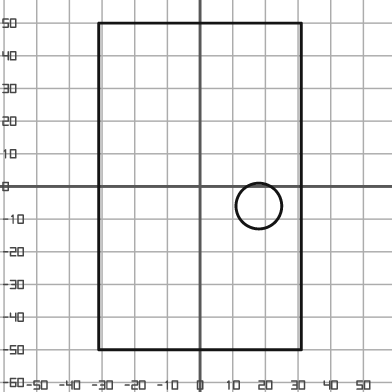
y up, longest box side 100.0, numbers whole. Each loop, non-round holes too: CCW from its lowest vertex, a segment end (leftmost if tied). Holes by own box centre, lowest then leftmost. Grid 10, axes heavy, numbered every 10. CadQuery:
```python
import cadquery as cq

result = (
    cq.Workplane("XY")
    .moveTo(-31.0, -50.0)
    .lineTo(31.0, -50.0)
    .lineTo(31.0, 50.0)
    .lineTo(-31.0, 50.0)
    .close()
    .moveTo(18.0, -6.0)
    .circle(7.0)
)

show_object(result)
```